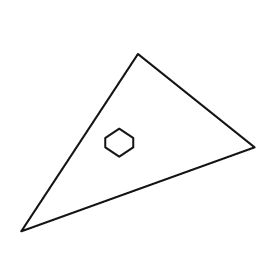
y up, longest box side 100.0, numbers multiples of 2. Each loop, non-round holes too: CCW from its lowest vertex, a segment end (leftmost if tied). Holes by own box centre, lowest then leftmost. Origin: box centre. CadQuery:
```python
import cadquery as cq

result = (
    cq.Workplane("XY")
    .moveTo(-50.0, -38.0)
    .lineTo(50.0, -2.0)
    .lineTo(0.0, 38.0)
    .close()
    .moveTo(-8.0, -6.0)
    .lineTo(-2.0, -2.0)
    .lineTo(-2.0, 2.0)
    .lineTo(-8.0, 6.0)
    .lineTo(-14.0, 2.0)
    .lineTo(-14.0, -2.0)
    .close()
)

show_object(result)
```